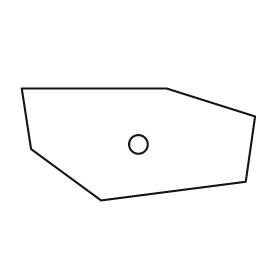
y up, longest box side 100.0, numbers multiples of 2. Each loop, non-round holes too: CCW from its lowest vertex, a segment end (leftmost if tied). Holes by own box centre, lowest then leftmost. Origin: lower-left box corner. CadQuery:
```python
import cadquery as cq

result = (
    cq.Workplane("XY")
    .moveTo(34.0, 0.0)
    .lineTo(96.0, 8.0)
    .lineTo(100.0, 36.0)
    .lineTo(62.0, 48.0)
    .lineTo(0.0, 48.0)
    .lineTo(4.0, 22.0)
    .close()
    .moveTo(50.0, 24.0)
    .circle(4.0)
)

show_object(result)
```